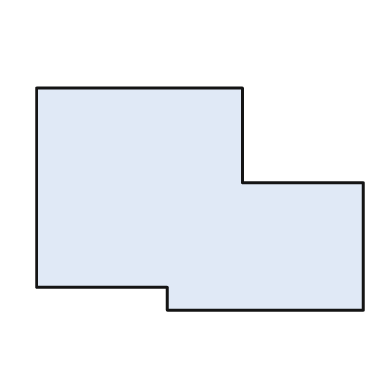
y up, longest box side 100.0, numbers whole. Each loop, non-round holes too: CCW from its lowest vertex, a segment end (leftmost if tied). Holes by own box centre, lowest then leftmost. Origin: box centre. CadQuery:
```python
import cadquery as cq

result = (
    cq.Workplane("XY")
    .moveTo(-10.0, -34.0)
    .lineTo(50.0, -34.0)
    .lineTo(50.0, 5.0)
    .lineTo(13.0, 5.0)
    .lineTo(13.0, 34.0)
    .lineTo(-50.0, 34.0)
    .lineTo(-50.0, -27.0)
    .lineTo(-10.0, -27.0)
    .close()
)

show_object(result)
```